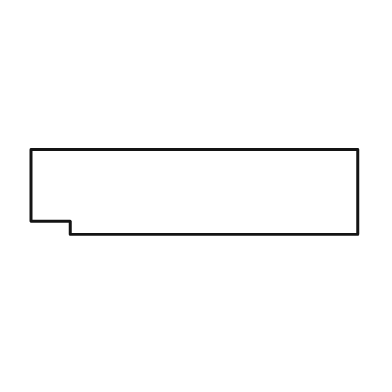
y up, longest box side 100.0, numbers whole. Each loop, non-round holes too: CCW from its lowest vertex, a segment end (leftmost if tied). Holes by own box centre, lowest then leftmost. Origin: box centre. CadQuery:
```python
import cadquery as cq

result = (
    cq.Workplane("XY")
    .moveTo(-38.0, -13.0)
    .lineTo(50.0, -13.0)
    .lineTo(50.0, 13.0)
    .lineTo(-50.0, 13.0)
    .lineTo(-50.0, -9.0)
    .lineTo(-38.0, -9.0)
    .close()
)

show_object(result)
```